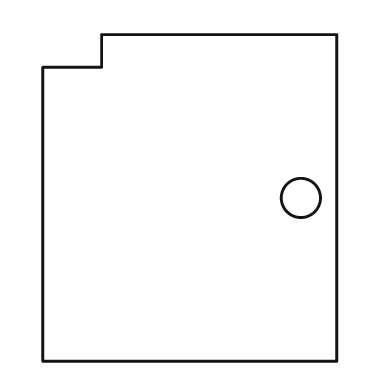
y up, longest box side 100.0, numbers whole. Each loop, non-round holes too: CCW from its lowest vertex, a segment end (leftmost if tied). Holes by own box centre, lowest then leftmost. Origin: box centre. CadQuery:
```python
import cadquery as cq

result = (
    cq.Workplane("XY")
    .moveTo(-45.0, -50.0)
    .lineTo(45.0, -50.0)
    .lineTo(45.0, 50.0)
    .lineTo(-27.0, 50.0)
    .lineTo(-27.0, 40.0)
    .lineTo(-45.0, 40.0)
    .close()
    .moveTo(34.0, 0.0)
    .circle(6.0)
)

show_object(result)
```